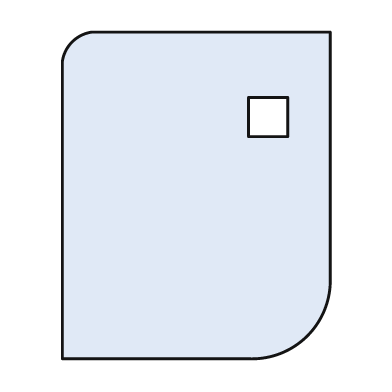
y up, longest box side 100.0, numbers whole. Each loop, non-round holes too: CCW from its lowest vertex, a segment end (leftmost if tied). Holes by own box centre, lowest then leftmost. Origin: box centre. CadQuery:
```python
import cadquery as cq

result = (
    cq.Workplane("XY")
    .moveTo(-41.0, -50.0)
    .lineTo(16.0, -50.0)
    .threePointArc((34.0, -43.0), (41.0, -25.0))
    .lineTo(41.0, 50.0)
    .lineTo(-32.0, 50.0)
    .threePointArc((-38.0, 47.0), (-41.0, 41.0))
    .close()
    .moveTo(16.0, 18.0)
    .lineTo(28.0, 18.0)
    .lineTo(28.0, 30.0)
    .lineTo(16.0, 30.0)
    .close()
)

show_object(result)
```